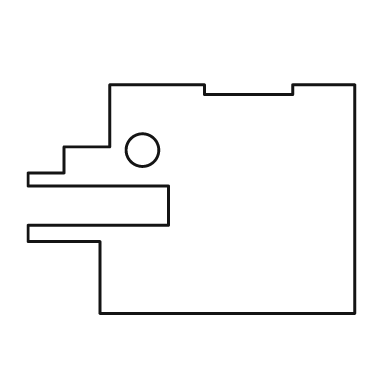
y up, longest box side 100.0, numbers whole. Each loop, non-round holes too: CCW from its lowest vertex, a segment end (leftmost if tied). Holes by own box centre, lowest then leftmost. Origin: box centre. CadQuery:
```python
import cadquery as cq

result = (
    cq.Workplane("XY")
    .moveTo(-28.0, -35.0)
    .lineTo(50.0, -35.0)
    .lineTo(50.0, 35.0)
    .lineTo(31.0, 35.0)
    .lineTo(31.0, 32.0)
    .lineTo(4.0, 32.0)
    .lineTo(4.0, 35.0)
    .lineTo(-25.0, 35.0)
    .lineTo(-25.0, 16.0)
    .lineTo(-39.0, 16.0)
    .lineTo(-39.0, 8.0)
    .lineTo(-50.0, 8.0)
    .lineTo(-50.0, 4.0)
    .lineTo(-7.0, 4.0)
    .lineTo(-7.0, -8.0)
    .lineTo(-50.0, -8.0)
    .lineTo(-50.0, -13.0)
    .lineTo(-28.0, -13.0)
    .close()
    .moveTo(-15.0, 15.0)
    .circle(5.0)
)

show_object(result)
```